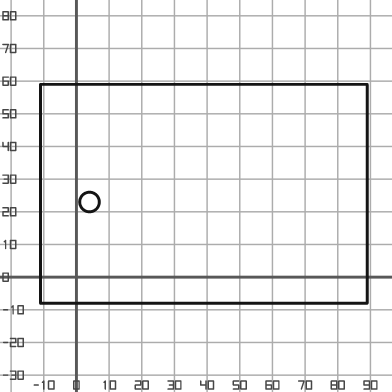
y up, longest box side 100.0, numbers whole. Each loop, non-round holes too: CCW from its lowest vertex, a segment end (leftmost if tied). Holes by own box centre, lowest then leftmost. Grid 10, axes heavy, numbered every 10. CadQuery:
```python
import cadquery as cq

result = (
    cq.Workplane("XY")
    .moveTo(-11.0, -8.0)
    .lineTo(89.0, -8.0)
    .lineTo(89.0, 59.0)
    .lineTo(-11.0, 59.0)
    .close()
    .moveTo(4.0, 23.0)
    .circle(3.0)
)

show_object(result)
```